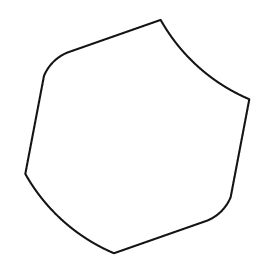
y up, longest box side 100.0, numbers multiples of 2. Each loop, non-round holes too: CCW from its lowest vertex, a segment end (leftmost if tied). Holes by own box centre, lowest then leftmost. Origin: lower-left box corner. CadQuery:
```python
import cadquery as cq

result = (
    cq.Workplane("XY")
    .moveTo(38.0, 0.0)
    .lineTo(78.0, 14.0)
    .threePointArc((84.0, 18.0), (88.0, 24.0))
    .lineTo(96.0, 66.0)
    .threePointArc((74.0, 80.0), (58.0, 100.0))
    .lineTo(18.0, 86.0)
    .threePointArc((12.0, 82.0), (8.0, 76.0))
    .lineTo(0.0, 34.0)
    .threePointArc((16.0, 14.0), (38.0, 0.0))
    .close()
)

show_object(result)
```